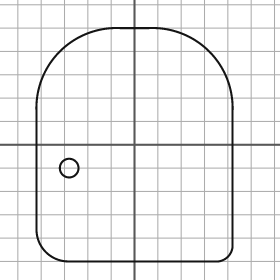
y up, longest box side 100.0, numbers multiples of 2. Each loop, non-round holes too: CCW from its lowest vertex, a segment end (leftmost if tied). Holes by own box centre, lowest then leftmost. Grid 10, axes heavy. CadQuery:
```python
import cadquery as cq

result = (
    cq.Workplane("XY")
    .moveTo(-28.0, -50.0)
    .lineTo(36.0, -50.0)
    .threePointArc((40.0, -48.0), (42.0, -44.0))
    .lineTo(42.0, 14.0)
    .threePointArc((32.0, 40.0), (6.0, 50.0))
    .lineTo(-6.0, 50.0)
    .threePointArc((-32.0, 40.0), (-42.0, 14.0))
    .lineTo(-42.0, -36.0)
    .threePointArc((-38.0, -46.0), (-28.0, -50.0))
    .close()
    .moveTo(-28.0, -10.0)
    .circle(4.0)
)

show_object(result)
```